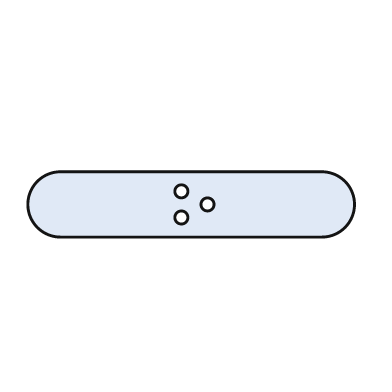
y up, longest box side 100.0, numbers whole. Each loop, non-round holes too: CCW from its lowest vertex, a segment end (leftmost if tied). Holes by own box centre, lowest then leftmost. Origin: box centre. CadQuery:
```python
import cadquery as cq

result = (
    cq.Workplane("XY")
    .moveTo(-40.0, -10.0)
    .lineTo(40.0, -10.0)
    .threePointArc((50.0, 0.0), (40.0, 10.0))
    .lineTo(-40.0, 10.0)
    .threePointArc((-50.0, 0.0), (-40.0, -10.0))
    .close()
    .moveTo(-3.0, -4.0)
    .circle(2.0)
    .moveTo(5.0, 0.0)
    .circle(2.0)
    .moveTo(-3.0, 4.0)
    .circle(2.0)
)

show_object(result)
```